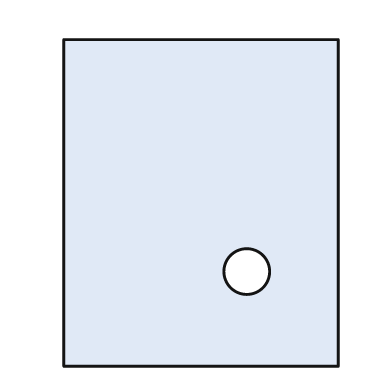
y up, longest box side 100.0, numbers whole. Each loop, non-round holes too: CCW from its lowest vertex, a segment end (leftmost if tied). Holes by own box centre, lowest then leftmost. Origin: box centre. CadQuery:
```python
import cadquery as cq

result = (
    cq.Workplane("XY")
    .moveTo(-42.0, -50.0)
    .lineTo(42.0, -50.0)
    .lineTo(42.0, 50.0)
    .lineTo(-42.0, 50.0)
    .close()
    .moveTo(14.0, -21.0)
    .circle(7.0)
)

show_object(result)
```